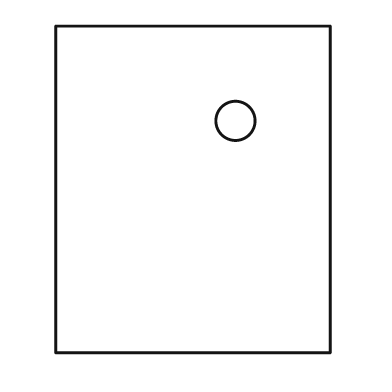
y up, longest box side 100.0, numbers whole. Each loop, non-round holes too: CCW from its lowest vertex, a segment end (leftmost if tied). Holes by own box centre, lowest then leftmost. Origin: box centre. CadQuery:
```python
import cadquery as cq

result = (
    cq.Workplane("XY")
    .moveTo(-42.0, -50.0)
    .lineTo(42.0, -50.0)
    .lineTo(42.0, 50.0)
    .lineTo(-42.0, 50.0)
    .close()
    .moveTo(13.0, 21.0)
    .circle(6.0)
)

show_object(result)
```